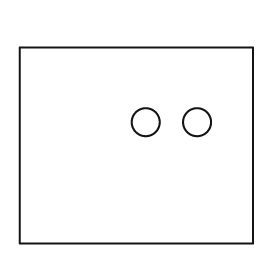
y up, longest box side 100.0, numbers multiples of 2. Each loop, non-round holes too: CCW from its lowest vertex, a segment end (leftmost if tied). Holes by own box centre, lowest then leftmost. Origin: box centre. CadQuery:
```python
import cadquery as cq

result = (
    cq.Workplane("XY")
    .moveTo(-50.0, -42.0)
    .lineTo(50.0, -42.0)
    .lineTo(50.0, 42.0)
    .lineTo(-50.0, 42.0)
    .close()
    .moveTo(4.0, 10.0)
    .circle(6.0)
    .moveTo(26.0, 10.0)
    .circle(6.0)
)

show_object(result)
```